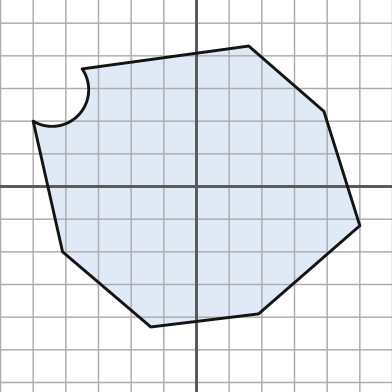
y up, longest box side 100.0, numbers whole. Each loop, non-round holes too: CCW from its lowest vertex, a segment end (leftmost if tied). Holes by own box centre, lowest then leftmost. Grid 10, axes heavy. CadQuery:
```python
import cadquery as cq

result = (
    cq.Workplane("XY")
    .moveTo(-14.0, -43.0)
    .lineTo(19.0, -39.0)
    .lineTo(50.0, -12.0)
    .lineTo(39.0, 23.0)
    .lineTo(16.0, 43.0)
    .lineTo(-35.0, 36.0)
    .threePointArc((-36.0, 22.0), (-50.0, 20.0))
    .lineTo(-41.0, -20.0)
    .close()
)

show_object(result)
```